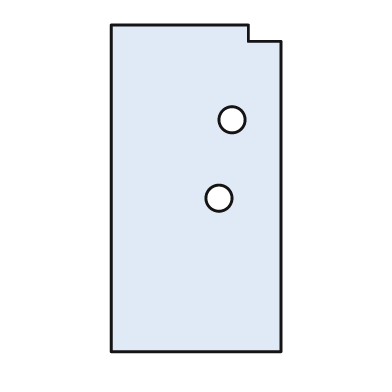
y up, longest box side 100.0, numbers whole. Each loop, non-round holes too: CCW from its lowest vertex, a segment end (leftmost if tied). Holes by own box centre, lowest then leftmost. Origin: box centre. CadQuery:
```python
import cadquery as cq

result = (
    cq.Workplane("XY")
    .moveTo(-26.0, -50.0)
    .lineTo(26.0, -50.0)
    .lineTo(26.0, 45.0)
    .lineTo(16.0, 45.0)
    .lineTo(16.0, 50.0)
    .lineTo(-26.0, 50.0)
    .close()
    .moveTo(7.0, -3.0)
    .circle(4.0)
    .moveTo(11.0, 21.0)
    .circle(4.0)
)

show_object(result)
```